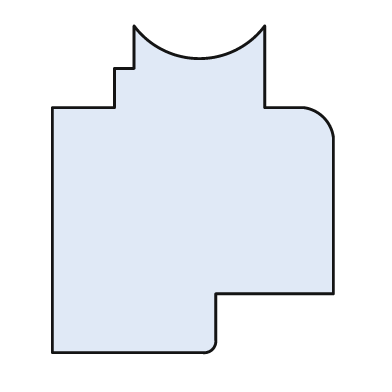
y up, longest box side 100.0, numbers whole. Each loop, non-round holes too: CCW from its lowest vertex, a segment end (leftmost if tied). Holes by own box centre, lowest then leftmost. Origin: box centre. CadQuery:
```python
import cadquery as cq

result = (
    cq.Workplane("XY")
    .moveTo(-43.0, -50.0)
    .lineTo(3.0, -50.0)
    .threePointArc((6.0, -49.0), (7.0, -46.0))
    .lineTo(7.0, -32.0)
    .lineTo(43.0, -32.0)
    .lineTo(43.0, 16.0)
    .threePointArc((40.0, 22.0), (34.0, 25.0))
    .lineTo(22.0, 25.0)
    .lineTo(22.0, 50.0)
    .threePointArc((2.0, 40.0), (-18.0, 50.0))
    .lineTo(-18.0, 37.0)
    .lineTo(-24.0, 37.0)
    .lineTo(-24.0, 25.0)
    .lineTo(-43.0, 25.0)
    .close()
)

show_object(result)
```